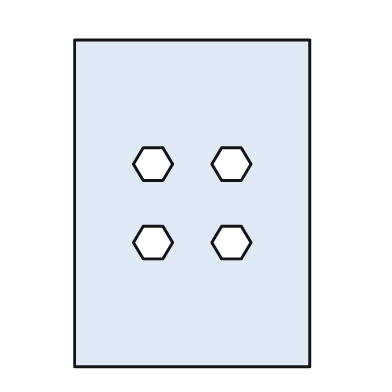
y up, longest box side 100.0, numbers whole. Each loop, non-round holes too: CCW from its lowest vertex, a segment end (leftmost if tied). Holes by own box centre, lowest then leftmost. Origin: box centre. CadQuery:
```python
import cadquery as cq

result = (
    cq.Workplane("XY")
    .moveTo(-36.0, -50.0)
    .lineTo(36.0, -50.0)
    .lineTo(36.0, 50.0)
    .lineTo(-36.0, 50.0)
    .close()
    .moveTo(-15.0, -17.0)
    .lineTo(-9.0, -17.0)
    .lineTo(-6.0, -12.0)
    .lineTo(-9.0, -7.0)
    .lineTo(-15.0, -7.0)
    .lineTo(-18.0, -12.0)
    .close()
    .moveTo(9.0, -17.0)
    .lineTo(15.0, -17.0)
    .lineTo(18.0, -12.0)
    .lineTo(15.0, -7.0)
    .lineTo(9.0, -7.0)
    .lineTo(6.0, -12.0)
    .close()
    .moveTo(-15.0, 7.0)
    .lineTo(-9.0, 7.0)
    .lineTo(-6.0, 12.0)
    .lineTo(-9.0, 17.0)
    .lineTo(-15.0, 17.0)
    .lineTo(-18.0, 12.0)
    .close()
    .moveTo(9.0, 7.0)
    .lineTo(15.0, 7.0)
    .lineTo(18.0, 12.0)
    .lineTo(15.0, 17.0)
    .lineTo(9.0, 17.0)
    .lineTo(6.0, 12.0)
    .close()
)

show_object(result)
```